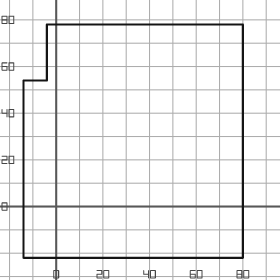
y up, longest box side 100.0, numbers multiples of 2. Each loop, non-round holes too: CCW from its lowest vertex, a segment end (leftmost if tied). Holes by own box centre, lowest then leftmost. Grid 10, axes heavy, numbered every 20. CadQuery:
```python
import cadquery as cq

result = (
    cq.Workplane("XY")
    .moveTo(-14.0, -22.0)
    .lineTo(80.0, -22.0)
    .lineTo(80.0, 78.0)
    .lineTo(-4.0, 78.0)
    .lineTo(-4.0, 54.0)
    .lineTo(-14.0, 54.0)
    .close()
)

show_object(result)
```